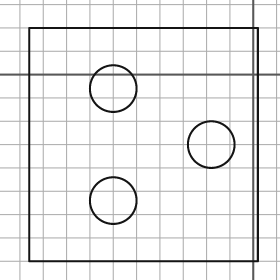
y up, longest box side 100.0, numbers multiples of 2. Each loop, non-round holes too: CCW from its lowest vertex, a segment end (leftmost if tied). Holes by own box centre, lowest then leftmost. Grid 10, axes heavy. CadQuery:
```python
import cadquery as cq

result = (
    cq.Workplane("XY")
    .moveTo(-96.0, -80.0)
    .lineTo(2.0, -80.0)
    .lineTo(2.0, 20.0)
    .lineTo(-96.0, 20.0)
    .close()
    .moveTo(-60.0, -54.0)
    .circle(10.0)
    .moveTo(-18.0, -30.0)
    .circle(10.0)
    .moveTo(-60.0, -6.0)
    .circle(10.0)
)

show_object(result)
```